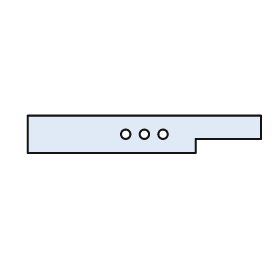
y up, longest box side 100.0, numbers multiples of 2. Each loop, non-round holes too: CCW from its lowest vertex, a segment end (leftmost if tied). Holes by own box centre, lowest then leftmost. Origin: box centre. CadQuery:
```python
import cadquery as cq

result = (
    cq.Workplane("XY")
    .moveTo(-50.0, -8.0)
    .lineTo(22.0, -8.0)
    .lineTo(22.0, -2.0)
    .lineTo(50.0, -2.0)
    .lineTo(50.0, 8.0)
    .lineTo(-50.0, 8.0)
    .close()
    .moveTo(-8.0, 0.0)
    .circle(2.0)
    .moveTo(0.0, 0.0)
    .circle(2.0)
    .moveTo(8.0, 0.0)
    .circle(2.0)
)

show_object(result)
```